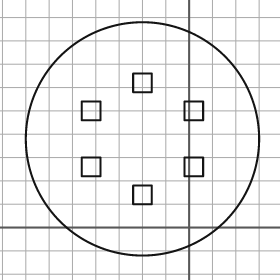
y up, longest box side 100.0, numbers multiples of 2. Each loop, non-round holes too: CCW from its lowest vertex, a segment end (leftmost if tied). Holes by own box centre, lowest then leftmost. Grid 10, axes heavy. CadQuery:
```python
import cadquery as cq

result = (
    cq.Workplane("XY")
    .moveTo(-20.0, 38.0)
    .circle(50.0)
    .moveTo(-24.0, 10.0)
    .lineTo(-16.0, 10.0)
    .lineTo(-16.0, 18.0)
    .lineTo(-24.0, 18.0)
    .close()
    .moveTo(-46.0, 22.0)
    .lineTo(-38.0, 22.0)
    .lineTo(-38.0, 30.0)
    .lineTo(-46.0, 30.0)
    .close()
    .moveTo(-2.0, 22.0)
    .lineTo(6.0, 22.0)
    .lineTo(6.0, 30.0)
    .lineTo(-2.0, 30.0)
    .close()
    .moveTo(-46.0, 46.0)
    .lineTo(-38.0, 46.0)
    .lineTo(-38.0, 54.0)
    .lineTo(-46.0, 54.0)
    .close()
    .moveTo(-2.0, 46.0)
    .lineTo(6.0, 46.0)
    .lineTo(6.0, 54.0)
    .lineTo(-2.0, 54.0)
    .close()
    .moveTo(-24.0, 58.0)
    .lineTo(-16.0, 58.0)
    .lineTo(-16.0, 66.0)
    .lineTo(-24.0, 66.0)
    .close()
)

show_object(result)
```